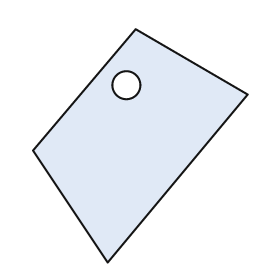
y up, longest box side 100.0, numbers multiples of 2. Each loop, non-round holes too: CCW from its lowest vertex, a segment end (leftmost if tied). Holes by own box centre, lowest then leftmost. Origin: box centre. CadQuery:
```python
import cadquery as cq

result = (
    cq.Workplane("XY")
    .moveTo(-14.0, -50.0)
    .lineTo(46.0, 22.0)
    .lineTo(-2.0, 50.0)
    .lineTo(-46.0, -2.0)
    .close()
    .moveTo(-6.0, 26.0)
    .circle(6.0)
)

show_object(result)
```